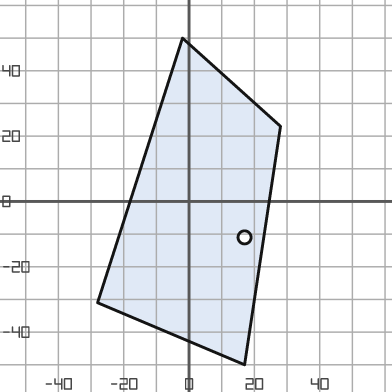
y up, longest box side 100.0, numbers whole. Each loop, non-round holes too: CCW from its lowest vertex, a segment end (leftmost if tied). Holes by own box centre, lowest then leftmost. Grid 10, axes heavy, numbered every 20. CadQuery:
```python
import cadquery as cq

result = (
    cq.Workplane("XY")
    .moveTo(17.0, -50.0)
    .lineTo(28.0, 23.0)
    .lineTo(-2.0, 50.0)
    .lineTo(-28.0, -31.0)
    .close()
    .moveTo(17.0, -11.0)
    .circle(2.0)
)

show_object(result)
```